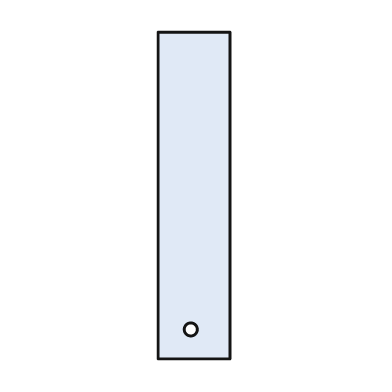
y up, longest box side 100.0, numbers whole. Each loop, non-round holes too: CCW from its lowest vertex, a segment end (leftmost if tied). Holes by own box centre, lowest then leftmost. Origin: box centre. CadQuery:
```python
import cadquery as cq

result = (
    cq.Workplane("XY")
    .moveTo(-11.0, -50.0)
    .lineTo(11.0, -50.0)
    .lineTo(11.0, 50.0)
    .lineTo(-11.0, 50.0)
    .close()
    .moveTo(-1.0, -41.0)
    .circle(2.0)
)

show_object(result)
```